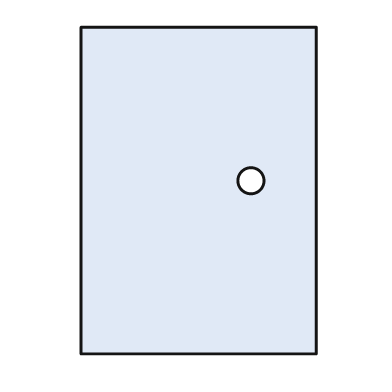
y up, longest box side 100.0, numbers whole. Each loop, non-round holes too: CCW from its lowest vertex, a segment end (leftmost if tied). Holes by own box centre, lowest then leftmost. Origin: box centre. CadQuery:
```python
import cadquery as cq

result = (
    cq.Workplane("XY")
    .moveTo(-36.0, -50.0)
    .lineTo(36.0, -50.0)
    .lineTo(36.0, 50.0)
    .lineTo(-36.0, 50.0)
    .close()
    .moveTo(16.0, 3.0)
    .circle(4.0)
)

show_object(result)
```